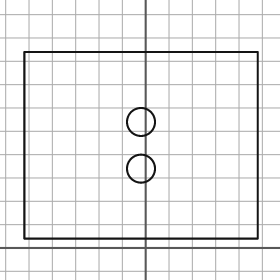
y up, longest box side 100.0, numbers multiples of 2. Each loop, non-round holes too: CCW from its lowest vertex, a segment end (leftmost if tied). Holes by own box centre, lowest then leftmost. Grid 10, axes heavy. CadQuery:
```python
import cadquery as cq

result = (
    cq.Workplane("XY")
    .moveTo(-52.0, 4.0)
    .lineTo(48.0, 4.0)
    .lineTo(48.0, 84.0)
    .lineTo(-52.0, 84.0)
    .close()
    .moveTo(-2.0, 34.0)
    .circle(6.0)
    .moveTo(-2.0, 54.0)
    .circle(6.0)
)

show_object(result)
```